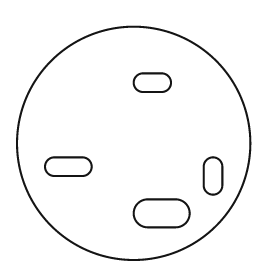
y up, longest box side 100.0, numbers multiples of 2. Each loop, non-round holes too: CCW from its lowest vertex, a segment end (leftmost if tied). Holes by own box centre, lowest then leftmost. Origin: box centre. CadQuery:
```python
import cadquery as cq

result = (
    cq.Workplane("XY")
    .moveTo(0.0, 0.0)
    .circle(50.0)
    .moveTo(6.0, -36.0)
    .lineTo(18.0, -36.0)
    .threePointArc((24.0, -30.0), (18.0, -24.0))
    .lineTo(6.0, -24.0)
    .threePointArc((0.0, -30.0), (6.0, -36.0))
    .close()
    .moveTo(30.0, -18.0)
    .threePointArc((34.0, -22.0), (38.0, -18.0))
    .lineTo(38.0, -10.0)
    .threePointArc((34.0, -6.0), (30.0, -10.0))
    .close()
    .moveTo(-34.0, -14.0)
    .lineTo(-22.0, -14.0)
    .threePointArc((-18.0, -10.0), (-22.0, -6.0))
    .lineTo(-34.0, -6.0)
    .threePointArc((-38.0, -10.0), (-34.0, -14.0))
    .close()
    .moveTo(4.0, 22.0)
    .lineTo(12.0, 22.0)
    .threePointArc((16.0, 26.0), (12.0, 30.0))
    .lineTo(4.0, 30.0)
    .threePointArc((0.0, 26.0), (4.0, 22.0))
    .close()
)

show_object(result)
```